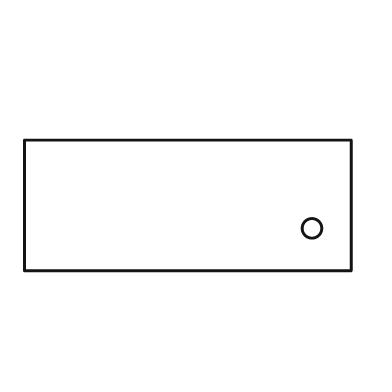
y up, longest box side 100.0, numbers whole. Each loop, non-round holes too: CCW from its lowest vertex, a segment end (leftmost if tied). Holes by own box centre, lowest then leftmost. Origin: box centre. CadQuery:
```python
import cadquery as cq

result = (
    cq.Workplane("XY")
    .moveTo(-50.0, -20.0)
    .lineTo(50.0, -20.0)
    .lineTo(50.0, 20.0)
    .lineTo(-50.0, 20.0)
    .close()
    .moveTo(38.0, -7.0)
    .circle(3.0)
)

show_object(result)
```